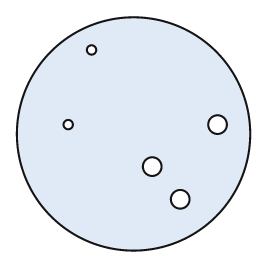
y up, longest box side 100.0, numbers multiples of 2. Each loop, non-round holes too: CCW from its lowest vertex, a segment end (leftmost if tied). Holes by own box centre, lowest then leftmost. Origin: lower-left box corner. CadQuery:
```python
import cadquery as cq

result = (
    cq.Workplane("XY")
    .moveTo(50.0, 50.0)
    .circle(50.0)
    .moveTo(70.0, 22.0)
    .circle(4.0)
    .moveTo(58.0, 36.0)
    .circle(4.0)
    .moveTo(22.0, 54.0)
    .circle(2.0)
    .moveTo(86.0, 54.0)
    .circle(4.0)
    .moveTo(32.0, 86.0)
    .circle(2.0)
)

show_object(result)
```